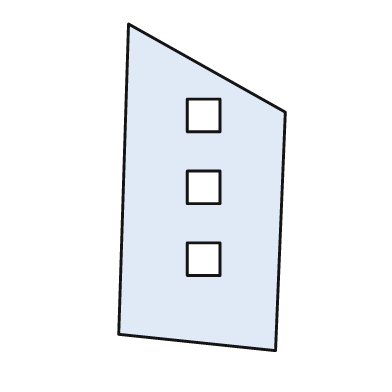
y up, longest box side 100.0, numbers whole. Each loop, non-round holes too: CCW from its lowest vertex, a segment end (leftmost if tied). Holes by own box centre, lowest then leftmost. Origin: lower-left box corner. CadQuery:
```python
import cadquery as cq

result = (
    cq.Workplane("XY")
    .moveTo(48.0, 0.0)
    .lineTo(51.0, 73.0)
    .lineTo(3.0, 100.0)
    .lineTo(0.0, 5.0)
    .close()
    .moveTo(21.0, 23.0)
    .lineTo(31.0, 23.0)
    .lineTo(31.0, 33.0)
    .lineTo(21.0, 33.0)
    .close()
    .moveTo(21.0, 45.0)
    .lineTo(31.0, 45.0)
    .lineTo(31.0, 55.0)
    .lineTo(21.0, 55.0)
    .close()
    .moveTo(21.0, 67.0)
    .lineTo(31.0, 67.0)
    .lineTo(31.0, 77.0)
    .lineTo(21.0, 77.0)
    .close()
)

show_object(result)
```